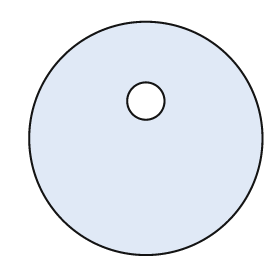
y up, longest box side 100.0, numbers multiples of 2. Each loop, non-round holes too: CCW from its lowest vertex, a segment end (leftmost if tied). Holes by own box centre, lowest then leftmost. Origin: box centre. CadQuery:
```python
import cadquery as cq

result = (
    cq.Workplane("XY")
    .moveTo(0.0, 0.0)
    .circle(50.0)
    .moveTo(0.0, 16.0)
    .circle(8.0)
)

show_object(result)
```